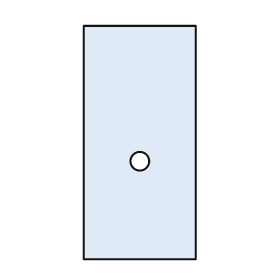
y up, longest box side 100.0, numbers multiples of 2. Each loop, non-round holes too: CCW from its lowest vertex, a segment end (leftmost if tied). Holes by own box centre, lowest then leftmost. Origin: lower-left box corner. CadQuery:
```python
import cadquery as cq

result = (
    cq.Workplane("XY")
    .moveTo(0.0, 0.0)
    .lineTo(48.0, 0.0)
    .lineTo(48.0, 100.0)
    .lineTo(0.0, 100.0)
    .close()
    .moveTo(24.0, 42.0)
    .circle(4.0)
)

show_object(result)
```